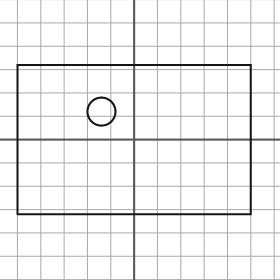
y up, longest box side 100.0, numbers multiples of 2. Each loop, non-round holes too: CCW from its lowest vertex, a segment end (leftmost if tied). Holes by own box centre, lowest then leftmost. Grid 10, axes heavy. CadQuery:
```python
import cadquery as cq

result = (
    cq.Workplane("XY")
    .moveTo(-50.0, -32.0)
    .lineTo(50.0, -32.0)
    .lineTo(50.0, 32.0)
    .lineTo(-50.0, 32.0)
    .close()
    .moveTo(-14.0, 12.0)
    .circle(6.0)
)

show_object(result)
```